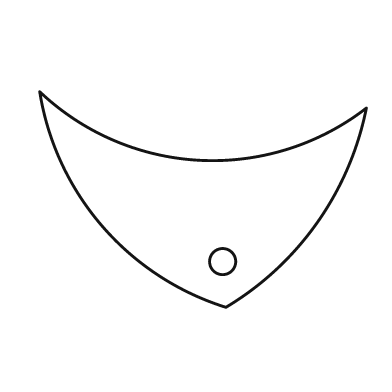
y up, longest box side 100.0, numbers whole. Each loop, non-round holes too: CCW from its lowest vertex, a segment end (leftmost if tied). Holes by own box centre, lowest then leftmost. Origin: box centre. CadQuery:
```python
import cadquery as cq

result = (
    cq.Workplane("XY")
    .moveTo(7.0, -33.0)
    .threePointArc((35.0, -7.0), (50.0, 28.0))
    .threePointArc((-1.0, 12.0), (-50.0, 33.0))
    .threePointArc((-31.0, -8.0), (7.0, -33.0))
    .close()
    .moveTo(6.0, -19.0)
    .circle(4.0)
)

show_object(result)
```